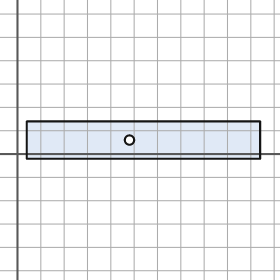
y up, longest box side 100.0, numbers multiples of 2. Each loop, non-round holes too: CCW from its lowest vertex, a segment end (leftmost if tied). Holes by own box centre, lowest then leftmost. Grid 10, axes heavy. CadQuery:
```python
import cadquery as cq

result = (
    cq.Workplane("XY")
    .moveTo(4.0, -2.0)
    .lineTo(104.0, -2.0)
    .lineTo(104.0, 14.0)
    .lineTo(4.0, 14.0)
    .close()
    .moveTo(48.0, 6.0)
    .circle(2.0)
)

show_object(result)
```